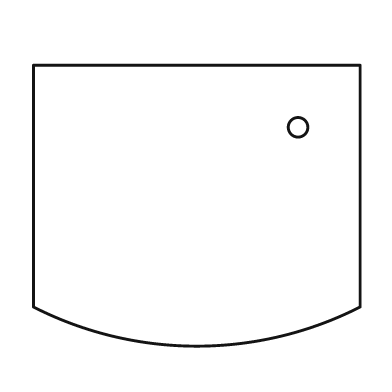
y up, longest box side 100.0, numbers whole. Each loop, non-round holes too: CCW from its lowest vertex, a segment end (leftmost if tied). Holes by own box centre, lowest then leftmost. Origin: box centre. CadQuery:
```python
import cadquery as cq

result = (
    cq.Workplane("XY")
    .moveTo(-50.0, -31.0)
    .threePointArc((0.0, -43.0), (50.0, -31.0))
    .lineTo(50.0, 43.0)
    .lineTo(-50.0, 43.0)
    .close()
    .moveTo(31.0, 24.0)
    .circle(3.0)
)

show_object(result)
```